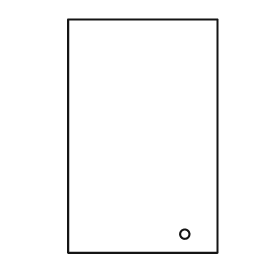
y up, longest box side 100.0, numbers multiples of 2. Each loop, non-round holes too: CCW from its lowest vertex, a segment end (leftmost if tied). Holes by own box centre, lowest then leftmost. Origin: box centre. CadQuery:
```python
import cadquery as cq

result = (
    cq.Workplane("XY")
    .moveTo(-32.0, -50.0)
    .lineTo(32.0, -50.0)
    .lineTo(32.0, 50.0)
    .lineTo(-32.0, 50.0)
    .close()
    .moveTo(18.0, -42.0)
    .circle(2.0)
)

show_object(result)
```